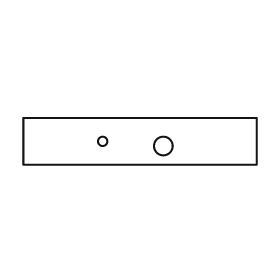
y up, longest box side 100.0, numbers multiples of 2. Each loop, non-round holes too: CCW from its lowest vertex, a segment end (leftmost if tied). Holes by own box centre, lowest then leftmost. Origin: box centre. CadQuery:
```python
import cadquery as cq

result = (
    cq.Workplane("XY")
    .moveTo(-50.0, -10.0)
    .lineTo(50.0, -10.0)
    .lineTo(50.0, 10.0)
    .lineTo(-50.0, 10.0)
    .close()
    .moveTo(10.0, -2.0)
    .circle(4.0)
    .moveTo(-16.0, 0.0)
    .circle(2.0)
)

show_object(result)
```